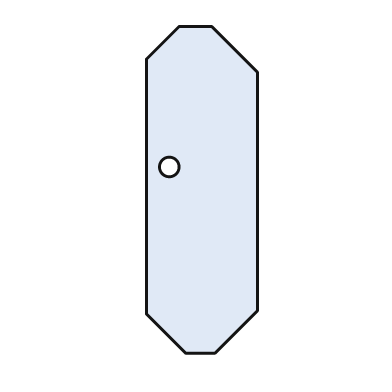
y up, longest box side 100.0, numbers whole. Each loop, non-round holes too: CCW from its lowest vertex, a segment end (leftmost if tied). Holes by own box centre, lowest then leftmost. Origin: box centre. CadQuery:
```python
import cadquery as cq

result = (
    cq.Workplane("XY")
    .moveTo(-5.0, -50.0)
    .lineTo(4.0, -50.0)
    .lineTo(17.0, -37.0)
    .lineTo(17.0, 36.0)
    .lineTo(3.0, 50.0)
    .lineTo(-7.0, 50.0)
    .lineTo(-17.0, 40.0)
    .lineTo(-17.0, -38.0)
    .close()
    .moveTo(-10.0, 7.0)
    .circle(3.0)
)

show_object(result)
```